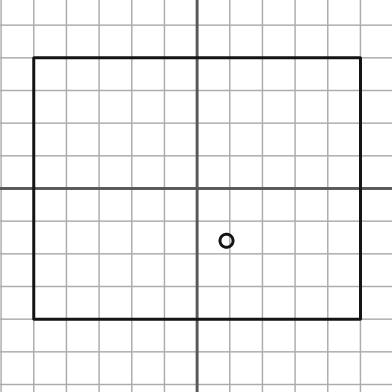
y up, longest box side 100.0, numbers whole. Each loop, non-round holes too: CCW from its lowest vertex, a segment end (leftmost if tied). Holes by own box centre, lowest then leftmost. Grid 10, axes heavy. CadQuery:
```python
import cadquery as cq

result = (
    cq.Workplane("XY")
    .moveTo(-50.0, -40.0)
    .lineTo(50.0, -40.0)
    .lineTo(50.0, 40.0)
    .lineTo(-50.0, 40.0)
    .close()
    .moveTo(9.0, -16.0)
    .circle(2.0)
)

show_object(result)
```